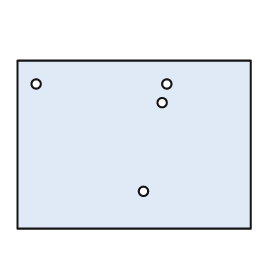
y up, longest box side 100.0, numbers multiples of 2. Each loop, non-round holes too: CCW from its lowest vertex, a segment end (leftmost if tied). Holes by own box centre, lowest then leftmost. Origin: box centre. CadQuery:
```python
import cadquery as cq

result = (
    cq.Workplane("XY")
    .moveTo(-50.0, -36.0)
    .lineTo(50.0, -36.0)
    .lineTo(50.0, 36.0)
    .lineTo(-50.0, 36.0)
    .close()
    .moveTo(4.0, -20.0)
    .circle(2.0)
    .moveTo(12.0, 18.0)
    .circle(2.0)
    .moveTo(-42.0, 26.0)
    .circle(2.0)
    .moveTo(14.0, 26.0)
    .circle(2.0)
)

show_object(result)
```